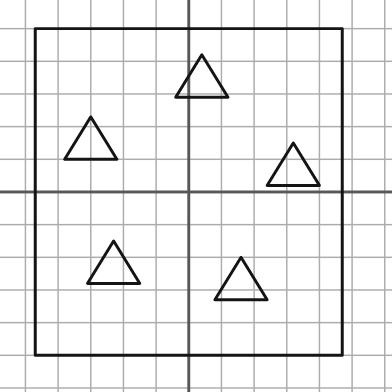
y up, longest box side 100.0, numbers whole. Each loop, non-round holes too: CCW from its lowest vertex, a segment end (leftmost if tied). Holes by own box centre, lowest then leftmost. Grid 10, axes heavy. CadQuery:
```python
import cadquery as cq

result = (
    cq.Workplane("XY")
    .moveTo(-47.0, -50.0)
    .lineTo(47.0, -50.0)
    .lineTo(47.0, 50.0)
    .lineTo(-47.0, 50.0)
    .close()
    .moveTo(8.0, -33.0)
    .lineTo(24.0, -33.0)
    .lineTo(16.0, -20.0)
    .close()
    .moveTo(-31.0, -28.0)
    .lineTo(-15.0, -28.0)
    .lineTo(-23.0, -15.0)
    .close()
    .moveTo(24.0, 2.0)
    .lineTo(40.0, 2.0)
    .lineTo(32.0, 15.0)
    .close()
    .moveTo(-38.0, 10.0)
    .lineTo(-22.0, 10.0)
    .lineTo(-30.0, 23.0)
    .close()
    .moveTo(-4.0, 29.0)
    .lineTo(12.0, 29.0)
    .lineTo(4.0, 42.0)
    .close()
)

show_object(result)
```